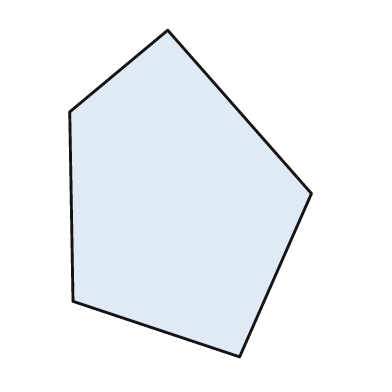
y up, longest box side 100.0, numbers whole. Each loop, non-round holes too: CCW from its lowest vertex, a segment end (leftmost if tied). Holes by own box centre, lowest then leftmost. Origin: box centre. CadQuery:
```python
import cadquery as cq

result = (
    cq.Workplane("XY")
    .moveTo(15.0, -50.0)
    .lineTo(37.0, 0.0)
    .lineTo(-7.0, 50.0)
    .lineTo(-37.0, 25.0)
    .lineTo(-36.0, -33.0)
    .close()
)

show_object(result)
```